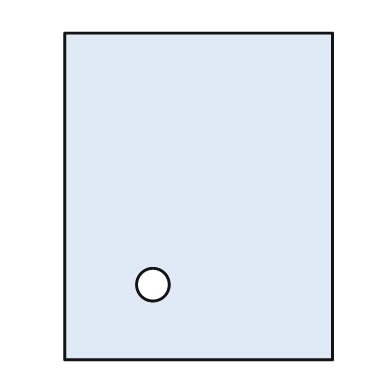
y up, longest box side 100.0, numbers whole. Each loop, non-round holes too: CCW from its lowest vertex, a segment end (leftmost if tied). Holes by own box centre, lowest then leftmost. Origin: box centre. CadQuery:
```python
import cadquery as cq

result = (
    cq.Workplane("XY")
    .moveTo(-41.0, -50.0)
    .lineTo(41.0, -50.0)
    .lineTo(41.0, 50.0)
    .lineTo(-41.0, 50.0)
    .close()
    .moveTo(-14.0, -27.0)
    .circle(5.0)
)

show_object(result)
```